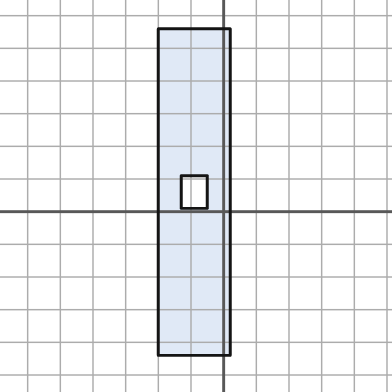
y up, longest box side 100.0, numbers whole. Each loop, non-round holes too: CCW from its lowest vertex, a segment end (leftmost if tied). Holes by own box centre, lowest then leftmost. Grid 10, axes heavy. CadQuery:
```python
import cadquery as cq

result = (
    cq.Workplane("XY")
    .moveTo(-20.0, -44.0)
    .lineTo(2.0, -44.0)
    .lineTo(2.0, 56.0)
    .lineTo(-20.0, 56.0)
    .close()
    .moveTo(-13.0, 1.0)
    .lineTo(-5.0, 1.0)
    .lineTo(-5.0, 11.0)
    .lineTo(-13.0, 11.0)
    .close()
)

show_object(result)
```